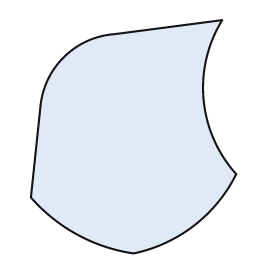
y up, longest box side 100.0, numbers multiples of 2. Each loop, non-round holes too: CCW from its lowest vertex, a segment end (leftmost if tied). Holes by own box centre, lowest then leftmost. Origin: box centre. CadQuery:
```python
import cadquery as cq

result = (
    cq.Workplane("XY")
    .moveTo(0.0, -50.0)
    .threePointArc((26.0, -38.0), (44.0, -16.0))
    .threePointArc((30.0, 16.0), (38.0, 50.0))
    .lineTo(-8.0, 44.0)
    .threePointArc((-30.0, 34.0), (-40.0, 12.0))
    .lineTo(-44.0, -26.0)
    .threePointArc((-24.0, -42.0), (0.0, -50.0))
    .close()
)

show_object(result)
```